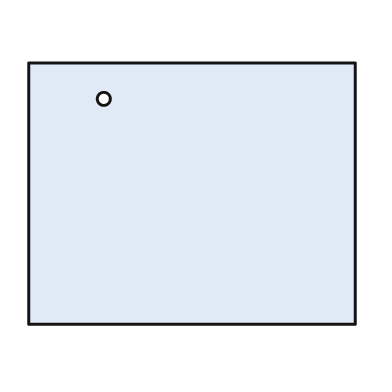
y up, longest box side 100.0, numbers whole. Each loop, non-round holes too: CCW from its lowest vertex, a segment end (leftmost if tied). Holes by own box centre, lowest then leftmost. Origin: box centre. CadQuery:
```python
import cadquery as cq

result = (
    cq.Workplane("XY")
    .moveTo(-50.0, -40.0)
    .lineTo(50.0, -40.0)
    .lineTo(50.0, 40.0)
    .lineTo(-50.0, 40.0)
    .close()
    .moveTo(-27.0, 29.0)
    .circle(2.0)
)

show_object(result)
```